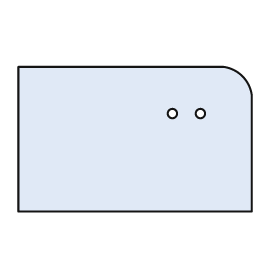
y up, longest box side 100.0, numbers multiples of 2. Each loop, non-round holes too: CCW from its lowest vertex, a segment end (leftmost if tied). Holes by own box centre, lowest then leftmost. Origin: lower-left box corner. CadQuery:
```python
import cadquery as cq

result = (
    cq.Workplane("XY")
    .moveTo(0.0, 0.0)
    .lineTo(100.0, 0.0)
    .lineTo(100.0, 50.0)
    .threePointArc((96.0, 58.0), (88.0, 62.0))
    .lineTo(0.0, 62.0)
    .close()
    .moveTo(66.0, 42.0)
    .circle(2.0)
    .moveTo(78.0, 42.0)
    .circle(2.0)
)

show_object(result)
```